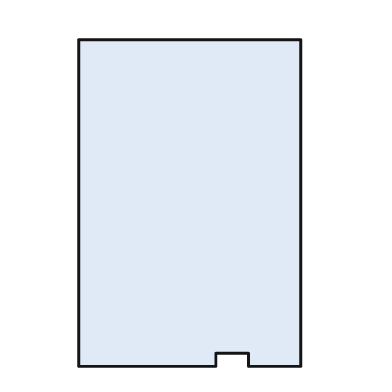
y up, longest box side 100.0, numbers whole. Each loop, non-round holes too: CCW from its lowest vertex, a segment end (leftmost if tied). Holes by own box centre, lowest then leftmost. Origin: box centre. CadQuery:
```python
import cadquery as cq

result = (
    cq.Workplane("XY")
    .moveTo(-34.0, -50.0)
    .lineTo(8.0, -50.0)
    .lineTo(8.0, -46.0)
    .lineTo(18.0, -46.0)
    .lineTo(18.0, -50.0)
    .lineTo(34.0, -50.0)
    .lineTo(34.0, 50.0)
    .lineTo(-34.0, 50.0)
    .close()
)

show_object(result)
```